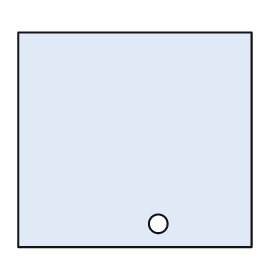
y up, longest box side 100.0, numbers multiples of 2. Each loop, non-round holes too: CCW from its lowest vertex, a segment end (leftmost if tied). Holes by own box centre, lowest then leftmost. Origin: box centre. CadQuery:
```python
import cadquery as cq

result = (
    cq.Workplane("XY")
    .moveTo(-50.0, -46.0)
    .lineTo(50.0, -46.0)
    .lineTo(50.0, 46.0)
    .lineTo(-50.0, 46.0)
    .close()
    .moveTo(10.0, -36.0)
    .circle(4.0)
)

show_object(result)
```